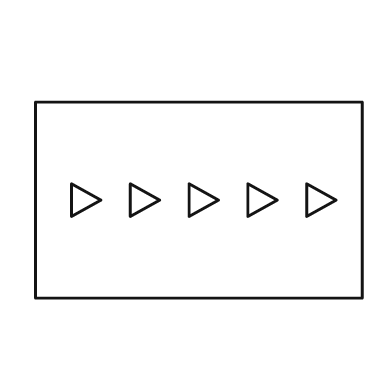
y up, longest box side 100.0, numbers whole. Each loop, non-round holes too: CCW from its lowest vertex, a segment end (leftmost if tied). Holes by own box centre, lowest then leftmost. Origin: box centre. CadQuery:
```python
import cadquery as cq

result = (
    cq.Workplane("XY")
    .moveTo(-50.0, -30.0)
    .lineTo(50.0, -30.0)
    .lineTo(50.0, 30.0)
    .lineTo(-50.0, 30.0)
    .close()
    .moveTo(-39.0, -5.0)
    .lineTo(-30.0, 0.0)
    .lineTo(-39.0, 5.0)
    .close()
    .moveTo(-21.0, -5.0)
    .lineTo(-12.0, 0.0)
    .lineTo(-21.0, 5.0)
    .close()
    .moveTo(-3.0, -5.0)
    .lineTo(6.0, 0.0)
    .lineTo(-3.0, 5.0)
    .close()
    .moveTo(15.0, -5.0)
    .lineTo(24.0, 0.0)
    .lineTo(15.0, 5.0)
    .close()
    .moveTo(33.0, -5.0)
    .lineTo(42.0, 0.0)
    .lineTo(33.0, 5.0)
    .close()
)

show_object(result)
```